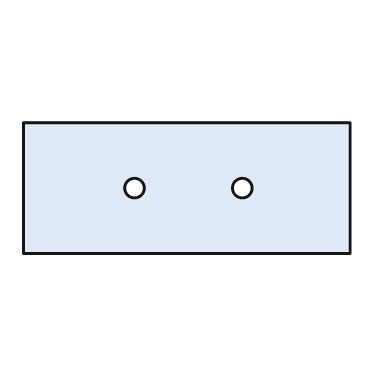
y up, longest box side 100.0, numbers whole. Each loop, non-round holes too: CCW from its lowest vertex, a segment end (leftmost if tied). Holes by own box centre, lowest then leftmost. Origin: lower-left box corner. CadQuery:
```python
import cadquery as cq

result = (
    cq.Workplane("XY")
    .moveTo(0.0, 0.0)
    .lineTo(100.0, 0.0)
    .lineTo(100.0, 40.0)
    .lineTo(0.0, 40.0)
    .close()
    .moveTo(34.0, 20.0)
    .circle(3.0)
    .moveTo(67.0, 20.0)
    .circle(3.0)
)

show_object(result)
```